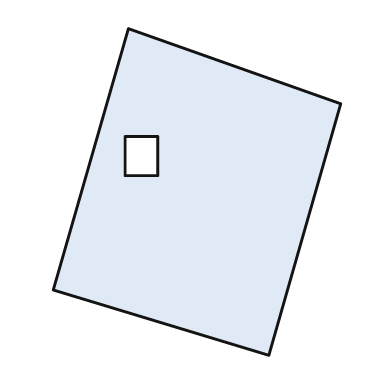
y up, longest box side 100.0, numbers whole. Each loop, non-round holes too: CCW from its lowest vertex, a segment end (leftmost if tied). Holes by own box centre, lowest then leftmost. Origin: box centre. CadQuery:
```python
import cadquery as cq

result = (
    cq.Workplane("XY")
    .moveTo(22.0, -50.0)
    .lineTo(44.0, 27.0)
    .lineTo(-21.0, 50.0)
    .lineTo(-44.0, -30.0)
    .close()
    .moveTo(-22.0, 5.0)
    .lineTo(-12.0, 5.0)
    .lineTo(-12.0, 17.0)
    .lineTo(-22.0, 17.0)
    .close()
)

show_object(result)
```